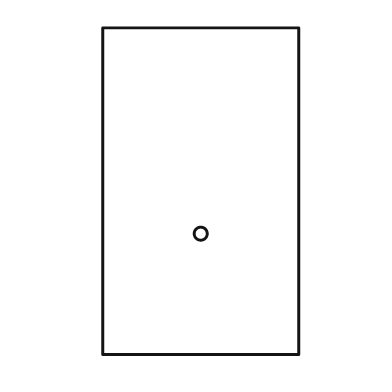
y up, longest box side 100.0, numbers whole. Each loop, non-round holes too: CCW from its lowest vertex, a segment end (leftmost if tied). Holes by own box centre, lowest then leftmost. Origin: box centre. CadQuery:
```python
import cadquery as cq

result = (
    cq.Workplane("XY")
    .moveTo(-30.0, -50.0)
    .lineTo(30.0, -50.0)
    .lineTo(30.0, 50.0)
    .lineTo(-30.0, 50.0)
    .close()
    .moveTo(0.0, -13.0)
    .circle(2.0)
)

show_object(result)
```